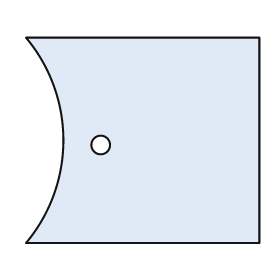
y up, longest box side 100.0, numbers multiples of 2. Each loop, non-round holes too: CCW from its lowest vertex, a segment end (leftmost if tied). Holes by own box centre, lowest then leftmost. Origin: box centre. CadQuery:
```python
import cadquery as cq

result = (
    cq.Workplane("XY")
    .moveTo(-50.0, -44.0)
    .lineTo(50.0, -44.0)
    .lineTo(50.0, 44.0)
    .lineTo(-50.0, 44.0)
    .threePointArc((-34.0, 0.0), (-50.0, -44.0))
    .close()
    .moveTo(-18.0, -2.0)
    .circle(4.0)
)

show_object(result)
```